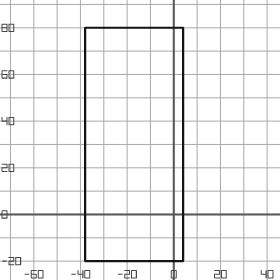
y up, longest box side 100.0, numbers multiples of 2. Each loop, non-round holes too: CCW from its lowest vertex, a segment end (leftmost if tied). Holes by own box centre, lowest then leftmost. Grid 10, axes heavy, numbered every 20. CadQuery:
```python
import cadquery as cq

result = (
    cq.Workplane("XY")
    .moveTo(-38.0, -20.0)
    .lineTo(4.0, -20.0)
    .lineTo(4.0, 80.0)
    .lineTo(-38.0, 80.0)
    .close()
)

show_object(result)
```